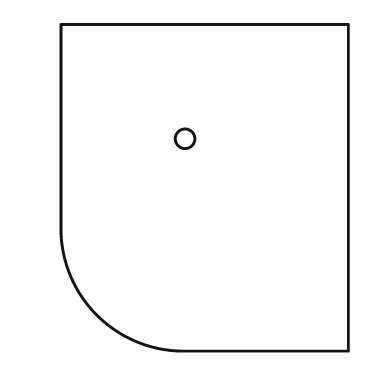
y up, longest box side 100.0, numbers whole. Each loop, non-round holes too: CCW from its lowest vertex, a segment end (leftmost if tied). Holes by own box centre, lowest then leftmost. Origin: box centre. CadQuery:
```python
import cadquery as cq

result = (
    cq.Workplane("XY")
    .moveTo(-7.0, -50.0)
    .lineTo(44.0, -50.0)
    .lineTo(44.0, 50.0)
    .lineTo(-44.0, 50.0)
    .lineTo(-44.0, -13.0)
    .threePointArc((-33.0, -39.0), (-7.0, -50.0))
    .close()
    .moveTo(-6.0, 15.0)
    .circle(3.0)
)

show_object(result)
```